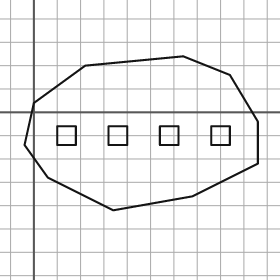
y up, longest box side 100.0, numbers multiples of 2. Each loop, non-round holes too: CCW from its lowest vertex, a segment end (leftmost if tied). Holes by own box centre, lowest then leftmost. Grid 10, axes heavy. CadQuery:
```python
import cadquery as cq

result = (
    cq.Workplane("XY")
    .moveTo(34.0, -42.0)
    .lineTo(68.0, -36.0)
    .lineTo(96.0, -22.0)
    .lineTo(96.0, -4.0)
    .lineTo(84.0, 16.0)
    .lineTo(64.0, 24.0)
    .lineTo(22.0, 20.0)
    .lineTo(0.0, 4.0)
    .lineTo(-4.0, -14.0)
    .lineTo(6.0, -28.0)
    .close()
    .moveTo(10.0, -14.0)
    .lineTo(18.0, -14.0)
    .lineTo(18.0, -6.0)
    .lineTo(10.0, -6.0)
    .close()
    .moveTo(32.0, -14.0)
    .lineTo(40.0, -14.0)
    .lineTo(40.0, -6.0)
    .lineTo(32.0, -6.0)
    .close()
    .moveTo(54.0, -14.0)
    .lineTo(62.0, -14.0)
    .lineTo(62.0, -6.0)
    .lineTo(54.0, -6.0)
    .close()
    .moveTo(76.0, -14.0)
    .lineTo(84.0, -14.0)
    .lineTo(84.0, -6.0)
    .lineTo(76.0, -6.0)
    .close()
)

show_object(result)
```